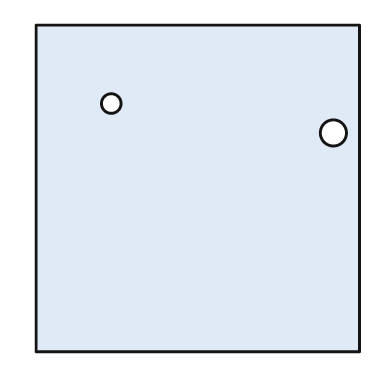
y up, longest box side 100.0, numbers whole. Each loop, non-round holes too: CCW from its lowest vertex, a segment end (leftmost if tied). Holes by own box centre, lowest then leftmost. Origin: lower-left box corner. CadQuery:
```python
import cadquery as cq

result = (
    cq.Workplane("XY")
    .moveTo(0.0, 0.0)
    .lineTo(99.0, 0.0)
    .lineTo(99.0, 100.0)
    .lineTo(0.0, 100.0)
    .close()
    .moveTo(91.0, 67.0)
    .circle(4.0)
    .moveTo(23.0, 76.0)
    .circle(3.0)
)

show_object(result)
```